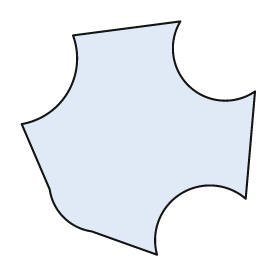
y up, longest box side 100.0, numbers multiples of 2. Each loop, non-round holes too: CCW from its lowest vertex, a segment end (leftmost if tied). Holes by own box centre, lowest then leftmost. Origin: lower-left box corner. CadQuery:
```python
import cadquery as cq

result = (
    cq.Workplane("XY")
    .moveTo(58.0, 0.0)
    .threePointArc((68.0, 26.0), (96.0, 24.0))
    .lineTo(100.0, 70.0)
    .threePointArc((72.0, 72.0), (68.0, 100.0))
    .lineTo(22.0, 94.0)
    .threePointArc((20.0, 70.0), (0.0, 56.0))
    .lineTo(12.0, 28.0)
    .threePointArc((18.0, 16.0), (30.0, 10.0))
    .close()
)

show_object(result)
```